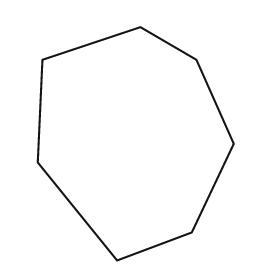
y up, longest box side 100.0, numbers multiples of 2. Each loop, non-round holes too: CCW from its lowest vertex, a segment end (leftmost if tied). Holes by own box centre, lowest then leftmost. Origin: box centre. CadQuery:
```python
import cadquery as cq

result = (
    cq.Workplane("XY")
    .moveTo(-8.0, -50.0)
    .lineTo(24.0, -38.0)
    .lineTo(42.0, 0.0)
    .lineTo(26.0, 36.0)
    .lineTo(2.0, 50.0)
    .lineTo(-40.0, 36.0)
    .lineTo(-42.0, -8.0)
    .close()
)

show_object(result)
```